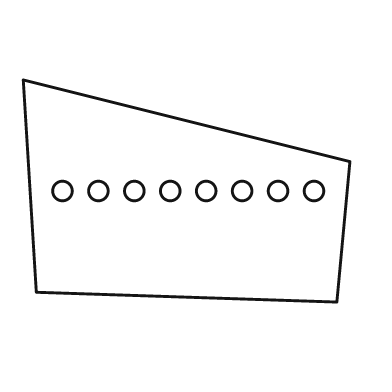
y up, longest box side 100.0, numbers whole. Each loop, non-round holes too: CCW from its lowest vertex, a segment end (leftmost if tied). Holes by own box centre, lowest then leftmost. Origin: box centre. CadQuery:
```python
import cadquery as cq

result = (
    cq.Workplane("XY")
    .moveTo(46.0, -34.0)
    .lineTo(50.0, 9.0)
    .lineTo(-50.0, 34.0)
    .lineTo(-46.0, -31.0)
    .close()
    .moveTo(-38.0, 0.0)
    .circle(3.0)
    .moveTo(-27.0, 0.0)
    .circle(3.0)
    .moveTo(-16.0, 0.0)
    .circle(3.0)
    .moveTo(-5.0, 0.0)
    .circle(3.0)
    .moveTo(6.0, 0.0)
    .circle(3.0)
    .moveTo(17.0, 0.0)
    .circle(3.0)
    .moveTo(28.0, 0.0)
    .circle(3.0)
    .moveTo(39.0, 0.0)
    .circle(3.0)
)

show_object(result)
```